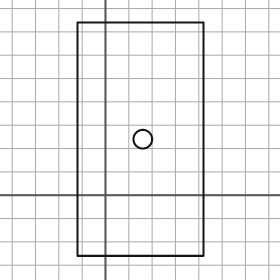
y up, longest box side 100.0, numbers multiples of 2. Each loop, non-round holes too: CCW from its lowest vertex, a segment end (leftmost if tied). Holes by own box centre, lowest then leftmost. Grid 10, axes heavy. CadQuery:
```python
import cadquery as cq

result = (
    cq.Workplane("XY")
    .moveTo(-12.0, -26.0)
    .lineTo(42.0, -26.0)
    .lineTo(42.0, 74.0)
    .lineTo(-12.0, 74.0)
    .close()
    .moveTo(16.0, 24.0)
    .circle(4.0)
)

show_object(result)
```